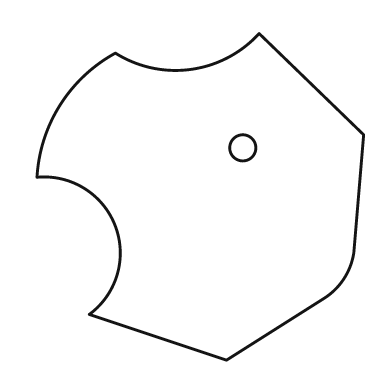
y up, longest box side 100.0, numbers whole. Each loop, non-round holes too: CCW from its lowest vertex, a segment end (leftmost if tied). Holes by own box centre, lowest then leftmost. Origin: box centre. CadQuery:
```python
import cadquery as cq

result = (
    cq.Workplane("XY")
    .moveTo(8.0, -50.0)
    .lineTo(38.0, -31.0)
    .threePointArc((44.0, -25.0), (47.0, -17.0))
    .lineTo(50.0, 19.0)
    .lineTo(18.0, 50.0)
    .threePointArc((-3.0, 39.0), (-26.0, 44.0))
    .threePointArc((-43.0, 28.0), (-50.0, 6.0))
    .threePointArc((-26.0, -9.0), (-34.0, -36.0))
    .close()
    .moveTo(13.0, 15.0)
    .circle(4.0)
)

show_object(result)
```